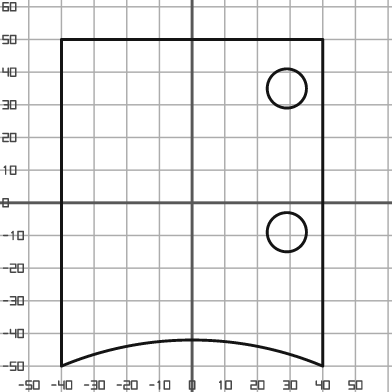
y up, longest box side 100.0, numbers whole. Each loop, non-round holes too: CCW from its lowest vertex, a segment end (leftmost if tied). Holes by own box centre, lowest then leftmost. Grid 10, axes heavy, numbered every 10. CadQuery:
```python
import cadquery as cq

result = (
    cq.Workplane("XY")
    .moveTo(-40.0, -50.0)
    .threePointArc((0.0, -42.0), (40.0, -50.0))
    .lineTo(40.0, 50.0)
    .lineTo(-40.0, 50.0)
    .close()
    .moveTo(29.0, -9.0)
    .circle(6.0)
    .moveTo(29.0, 35.0)
    .circle(6.0)
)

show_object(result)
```